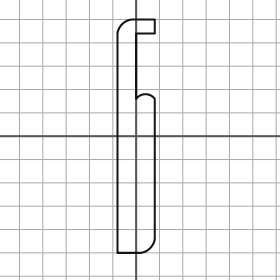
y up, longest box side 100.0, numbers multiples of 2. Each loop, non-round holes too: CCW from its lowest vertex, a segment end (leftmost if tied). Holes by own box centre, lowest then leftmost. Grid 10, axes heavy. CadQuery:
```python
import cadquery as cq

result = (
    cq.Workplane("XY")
    .moveTo(-8.0, -50.0)
    .lineTo(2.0, -50.0)
    .threePointArc((6.0, -48.0), (8.0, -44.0))
    .lineTo(8.0, 16.0)
    .threePointArc((4.0, 18.0), (0.0, 16.0))
    .lineTo(0.0, 44.0)
    .lineTo(8.0, 44.0)
    .lineTo(8.0, 50.0)
    .lineTo(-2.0, 50.0)
    .threePointArc((-6.0, 48.0), (-8.0, 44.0))
    .close()
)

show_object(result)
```